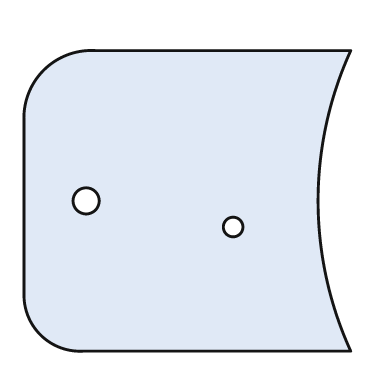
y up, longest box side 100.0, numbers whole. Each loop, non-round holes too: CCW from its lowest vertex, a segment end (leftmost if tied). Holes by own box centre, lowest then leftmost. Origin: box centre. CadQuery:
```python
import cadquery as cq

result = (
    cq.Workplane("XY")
    .moveTo(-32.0, -46.0)
    .lineTo(50.0, -46.0)
    .threePointArc((40.0, 0.0), (50.0, 46.0))
    .lineTo(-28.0, 46.0)
    .threePointArc((-44.0, 40.0), (-50.0, 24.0))
    .lineTo(-50.0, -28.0)
    .threePointArc((-45.0, -41.0), (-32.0, -46.0))
    .close()
    .moveTo(14.0, -8.0)
    .circle(3.0)
    .moveTo(-31.0, 0.0)
    .circle(4.0)
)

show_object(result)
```